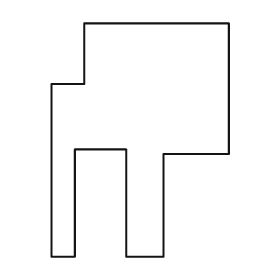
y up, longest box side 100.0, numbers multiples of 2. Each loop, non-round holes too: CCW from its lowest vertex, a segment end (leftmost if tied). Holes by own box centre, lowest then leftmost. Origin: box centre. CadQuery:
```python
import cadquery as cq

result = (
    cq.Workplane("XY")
    .moveTo(-38.0, -50.0)
    .lineTo(-28.0, -50.0)
    .lineTo(-28.0, -4.0)
    .lineTo(-6.0, -4.0)
    .lineTo(-6.0, -50.0)
    .lineTo(10.0, -50.0)
    .lineTo(10.0, -6.0)
    .lineTo(38.0, -6.0)
    .lineTo(38.0, 50.0)
    .lineTo(-24.0, 50.0)
    .lineTo(-24.0, 24.0)
    .lineTo(-38.0, 24.0)
    .close()
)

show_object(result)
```